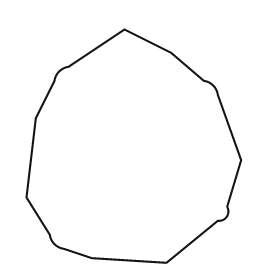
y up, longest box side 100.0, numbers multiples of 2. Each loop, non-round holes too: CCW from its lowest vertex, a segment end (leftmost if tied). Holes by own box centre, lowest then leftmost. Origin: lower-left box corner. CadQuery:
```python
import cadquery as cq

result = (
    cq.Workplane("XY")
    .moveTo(60.0, 0.0)
    .lineTo(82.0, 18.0)
    .threePointArc((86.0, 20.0), (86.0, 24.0))
    .lineTo(92.0, 44.0)
    .lineTo(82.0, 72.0)
    .threePointArc((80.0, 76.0), (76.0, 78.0))
    .lineTo(62.0, 90.0)
    .lineTo(42.0, 100.0)
    .lineTo(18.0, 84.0)
    .threePointArc((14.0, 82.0), (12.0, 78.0))
    .lineTo(4.0, 62.0)
    .lineTo(0.0, 28.0)
    .lineTo(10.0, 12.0)
    .threePointArc((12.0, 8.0), (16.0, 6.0))
    .lineTo(28.0, 2.0)
    .close()
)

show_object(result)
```